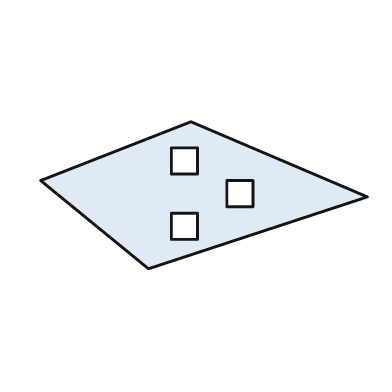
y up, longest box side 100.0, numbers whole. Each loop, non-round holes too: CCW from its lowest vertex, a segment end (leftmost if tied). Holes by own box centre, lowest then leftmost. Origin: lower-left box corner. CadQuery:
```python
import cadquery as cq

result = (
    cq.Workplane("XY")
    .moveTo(33.0, 0.0)
    .lineTo(100.0, 22.0)
    .lineTo(46.0, 45.0)
    .lineTo(0.0, 27.0)
    .close()
    .moveTo(40.0, 9.0)
    .lineTo(48.0, 9.0)
    .lineTo(48.0, 17.0)
    .lineTo(40.0, 17.0)
    .close()
    .moveTo(57.0, 19.0)
    .lineTo(65.0, 19.0)
    .lineTo(65.0, 27.0)
    .lineTo(57.0, 27.0)
    .close()
    .moveTo(40.0, 29.0)
    .lineTo(48.0, 29.0)
    .lineTo(48.0, 37.0)
    .lineTo(40.0, 37.0)
    .close()
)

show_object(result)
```